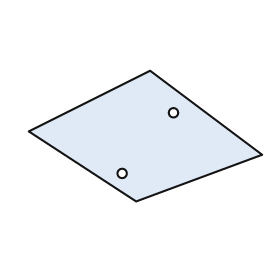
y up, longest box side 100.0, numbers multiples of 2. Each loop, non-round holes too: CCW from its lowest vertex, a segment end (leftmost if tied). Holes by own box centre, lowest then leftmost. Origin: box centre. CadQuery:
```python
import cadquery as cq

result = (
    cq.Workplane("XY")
    .moveTo(-4.0, -28.0)
    .lineTo(50.0, -8.0)
    .lineTo(2.0, 28.0)
    .lineTo(-50.0, 2.0)
    .close()
    .moveTo(-10.0, -16.0)
    .circle(2.0)
    .moveTo(12.0, 10.0)
    .circle(2.0)
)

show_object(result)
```